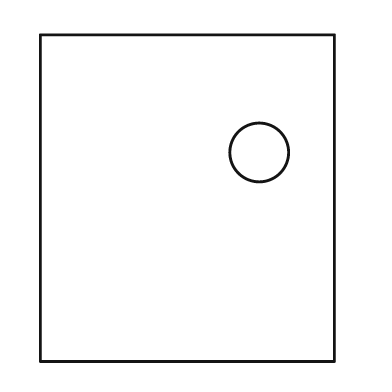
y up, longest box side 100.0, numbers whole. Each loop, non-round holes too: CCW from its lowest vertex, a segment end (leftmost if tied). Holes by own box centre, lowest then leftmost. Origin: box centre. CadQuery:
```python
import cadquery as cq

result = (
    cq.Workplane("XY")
    .moveTo(-45.0, -50.0)
    .lineTo(45.0, -50.0)
    .lineTo(45.0, 50.0)
    .lineTo(-45.0, 50.0)
    .close()
    .moveTo(22.0, 14.0)
    .circle(9.0)
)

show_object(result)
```